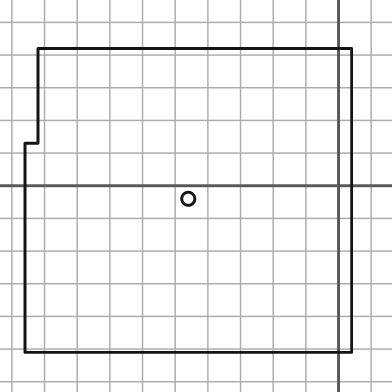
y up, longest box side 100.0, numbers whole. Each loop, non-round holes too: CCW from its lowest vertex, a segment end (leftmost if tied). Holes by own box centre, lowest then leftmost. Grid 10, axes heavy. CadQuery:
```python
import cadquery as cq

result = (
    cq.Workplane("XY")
    .moveTo(-96.0, -51.0)
    .lineTo(4.0, -51.0)
    .lineTo(4.0, 42.0)
    .lineTo(-92.0, 42.0)
    .lineTo(-92.0, 13.0)
    .lineTo(-96.0, 13.0)
    .close()
    .moveTo(-46.0, -4.0)
    .circle(2.0)
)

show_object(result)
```